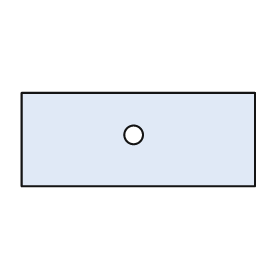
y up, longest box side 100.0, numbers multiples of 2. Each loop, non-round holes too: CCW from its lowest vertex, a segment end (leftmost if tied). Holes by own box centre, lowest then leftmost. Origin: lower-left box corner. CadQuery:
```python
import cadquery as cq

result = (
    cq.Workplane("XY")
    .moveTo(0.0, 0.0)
    .lineTo(100.0, 0.0)
    .lineTo(100.0, 40.0)
    .lineTo(0.0, 40.0)
    .close()
    .moveTo(48.0, 22.0)
    .circle(4.0)
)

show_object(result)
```